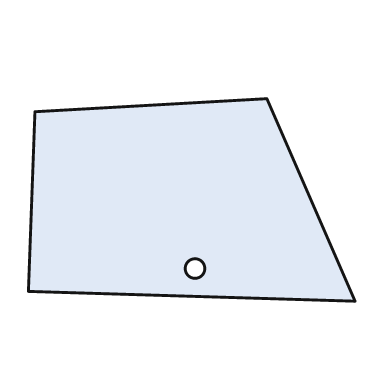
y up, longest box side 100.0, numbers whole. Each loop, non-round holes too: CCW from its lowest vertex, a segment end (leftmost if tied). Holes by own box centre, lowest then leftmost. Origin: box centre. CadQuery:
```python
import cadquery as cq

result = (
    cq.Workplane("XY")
    .moveTo(50.0, -31.0)
    .lineTo(23.0, 31.0)
    .lineTo(-48.0, 27.0)
    .lineTo(-50.0, -28.0)
    .close()
    .moveTo(1.0, -21.0)
    .circle(3.0)
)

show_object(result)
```